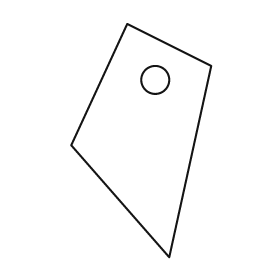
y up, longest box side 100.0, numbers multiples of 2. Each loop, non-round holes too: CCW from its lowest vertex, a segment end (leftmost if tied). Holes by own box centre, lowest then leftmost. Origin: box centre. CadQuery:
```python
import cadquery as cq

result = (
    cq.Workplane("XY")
    .moveTo(12.0, -50.0)
    .lineTo(30.0, 32.0)
    .lineTo(-6.0, 50.0)
    .lineTo(-30.0, -2.0)
    .close()
    .moveTo(6.0, 26.0)
    .circle(6.0)
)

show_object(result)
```